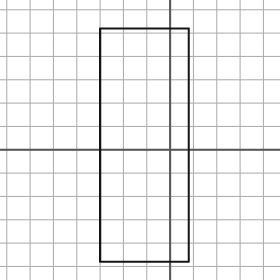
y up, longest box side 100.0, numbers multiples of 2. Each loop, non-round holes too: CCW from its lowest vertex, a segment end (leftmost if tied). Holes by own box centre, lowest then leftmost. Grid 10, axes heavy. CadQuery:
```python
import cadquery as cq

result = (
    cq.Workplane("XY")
    .moveTo(-30.0, -48.0)
    .lineTo(8.0, -48.0)
    .lineTo(8.0, 52.0)
    .lineTo(-30.0, 52.0)
    .close()
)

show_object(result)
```